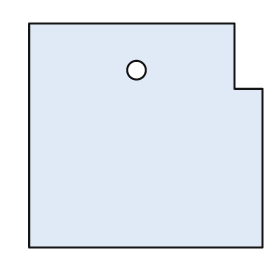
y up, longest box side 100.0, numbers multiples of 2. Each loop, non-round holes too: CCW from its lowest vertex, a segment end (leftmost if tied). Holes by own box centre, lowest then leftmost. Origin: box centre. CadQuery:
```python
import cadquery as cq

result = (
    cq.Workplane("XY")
    .moveTo(-50.0, -48.0)
    .lineTo(50.0, -48.0)
    .lineTo(50.0, 20.0)
    .lineTo(38.0, 20.0)
    .lineTo(38.0, 48.0)
    .lineTo(-50.0, 48.0)
    .close()
    .moveTo(-4.0, 28.0)
    .circle(4.0)
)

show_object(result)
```